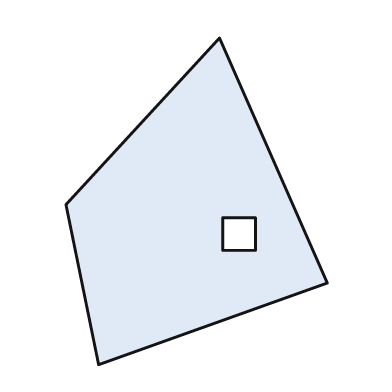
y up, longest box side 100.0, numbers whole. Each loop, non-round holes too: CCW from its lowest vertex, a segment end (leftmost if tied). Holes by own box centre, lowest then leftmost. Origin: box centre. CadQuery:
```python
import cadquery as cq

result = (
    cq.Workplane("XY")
    .moveTo(-30.0, -50.0)
    .lineTo(40.0, -25.0)
    .lineTo(7.0, 50.0)
    .lineTo(-40.0, -1.0)
    .close()
    .moveTo(8.0, -15.0)
    .lineTo(18.0, -15.0)
    .lineTo(18.0, -5.0)
    .lineTo(8.0, -5.0)
    .close()
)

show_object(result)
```